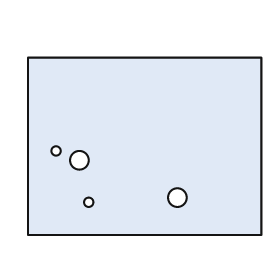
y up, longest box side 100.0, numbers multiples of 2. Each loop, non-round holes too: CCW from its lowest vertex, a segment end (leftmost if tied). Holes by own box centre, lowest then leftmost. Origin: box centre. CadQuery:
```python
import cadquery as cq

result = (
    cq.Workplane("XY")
    .moveTo(-50.0, -38.0)
    .lineTo(50.0, -38.0)
    .lineTo(50.0, 38.0)
    .lineTo(-50.0, 38.0)
    .close()
    .moveTo(-24.0, -24.0)
    .circle(2.0)
    .moveTo(14.0, -22.0)
    .circle(4.0)
    .moveTo(-28.0, -6.0)
    .circle(4.0)
    .moveTo(-38.0, -2.0)
    .circle(2.0)
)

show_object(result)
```